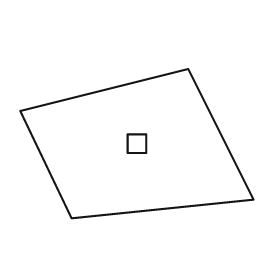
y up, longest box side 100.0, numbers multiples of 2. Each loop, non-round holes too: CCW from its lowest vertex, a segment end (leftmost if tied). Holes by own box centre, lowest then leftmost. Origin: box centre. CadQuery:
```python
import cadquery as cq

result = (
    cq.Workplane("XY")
    .moveTo(-28.0, -32.0)
    .lineTo(50.0, -24.0)
    .lineTo(22.0, 32.0)
    .lineTo(-50.0, 14.0)
    .close()
    .moveTo(-4.0, -4.0)
    .lineTo(4.0, -4.0)
    .lineTo(4.0, 4.0)
    .lineTo(-4.0, 4.0)
    .close()
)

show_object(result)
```